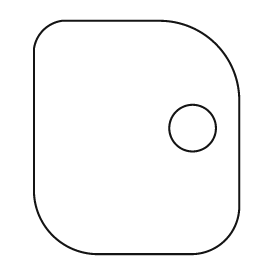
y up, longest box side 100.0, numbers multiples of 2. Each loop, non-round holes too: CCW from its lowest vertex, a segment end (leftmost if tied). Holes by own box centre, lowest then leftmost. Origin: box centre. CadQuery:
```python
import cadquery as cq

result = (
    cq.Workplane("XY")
    .moveTo(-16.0, -50.0)
    .lineTo(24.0, -50.0)
    .threePointArc((38.0, -44.0), (44.0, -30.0))
    .lineTo(44.0, 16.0)
    .threePointArc((34.0, 40.0), (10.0, 50.0))
    .lineTo(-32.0, 50.0)
    .threePointArc((-40.0, 46.0), (-44.0, 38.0))
    .lineTo(-44.0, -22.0)
    .threePointArc((-36.0, -42.0), (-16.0, -50.0))
    .close()
    .moveTo(24.0, 4.0)
    .circle(10.0)
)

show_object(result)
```